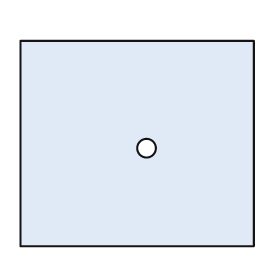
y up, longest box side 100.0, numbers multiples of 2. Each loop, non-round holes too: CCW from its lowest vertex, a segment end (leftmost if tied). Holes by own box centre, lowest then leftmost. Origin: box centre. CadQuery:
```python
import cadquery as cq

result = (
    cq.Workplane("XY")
    .moveTo(-50.0, -44.0)
    .lineTo(50.0, -44.0)
    .lineTo(50.0, 44.0)
    .lineTo(-50.0, 44.0)
    .close()
    .moveTo(4.0, -2.0)
    .circle(4.0)
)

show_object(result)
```